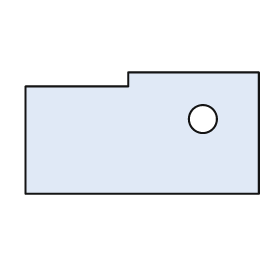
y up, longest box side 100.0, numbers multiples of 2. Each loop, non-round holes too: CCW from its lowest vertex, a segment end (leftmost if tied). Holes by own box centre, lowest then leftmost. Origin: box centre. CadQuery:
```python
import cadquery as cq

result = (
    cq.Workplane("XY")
    .moveTo(-50.0, -26.0)
    .lineTo(50.0, -26.0)
    .lineTo(50.0, 26.0)
    .lineTo(-6.0, 26.0)
    .lineTo(-6.0, 20.0)
    .lineTo(-50.0, 20.0)
    .close()
    .moveTo(26.0, 6.0)
    .circle(6.0)
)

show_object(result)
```